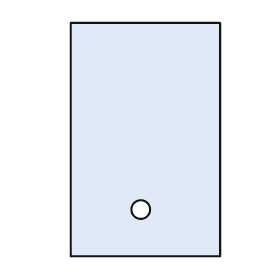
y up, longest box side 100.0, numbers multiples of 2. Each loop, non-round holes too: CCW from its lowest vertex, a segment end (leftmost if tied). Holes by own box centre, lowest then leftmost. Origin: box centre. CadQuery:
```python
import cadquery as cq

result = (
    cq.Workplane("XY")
    .moveTo(-32.0, -50.0)
    .lineTo(32.0, -50.0)
    .lineTo(32.0, 50.0)
    .lineTo(-32.0, 50.0)
    .close()
    .moveTo(-2.0, -30.0)
    .circle(4.0)
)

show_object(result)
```